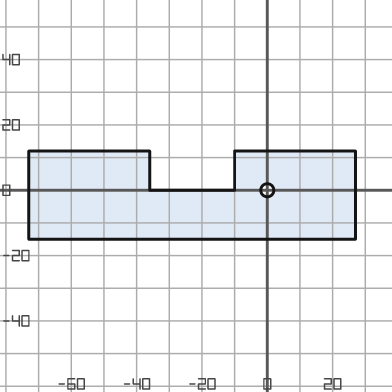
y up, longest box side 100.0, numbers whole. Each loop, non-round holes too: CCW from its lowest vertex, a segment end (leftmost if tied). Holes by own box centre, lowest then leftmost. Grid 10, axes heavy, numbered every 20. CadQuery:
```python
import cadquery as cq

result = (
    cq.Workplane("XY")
    .moveTo(-73.0, -15.0)
    .lineTo(27.0, -15.0)
    .lineTo(27.0, 12.0)
    .lineTo(-10.0, 12.0)
    .lineTo(-10.0, 0.0)
    .lineTo(-36.0, 0.0)
    .lineTo(-36.0, 12.0)
    .lineTo(-73.0, 12.0)
    .close()
    .moveTo(0.0, 0.0)
    .circle(2.0)
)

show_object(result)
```